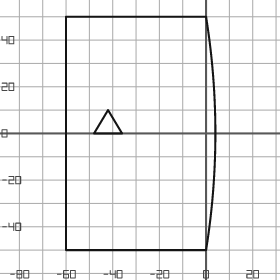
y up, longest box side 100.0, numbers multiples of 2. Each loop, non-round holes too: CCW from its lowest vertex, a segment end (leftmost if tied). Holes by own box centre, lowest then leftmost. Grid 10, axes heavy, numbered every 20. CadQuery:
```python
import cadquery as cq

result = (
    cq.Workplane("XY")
    .moveTo(-60.0, -50.0)
    .lineTo(0.0, -50.0)
    .threePointArc((4.0, 0.0), (0.0, 50.0))
    .lineTo(-60.0, 50.0)
    .close()
    .moveTo(-48.0, 0.0)
    .lineTo(-36.0, 0.0)
    .lineTo(-42.0, 10.0)
    .close()
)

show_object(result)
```